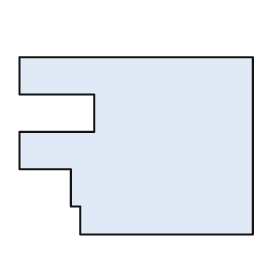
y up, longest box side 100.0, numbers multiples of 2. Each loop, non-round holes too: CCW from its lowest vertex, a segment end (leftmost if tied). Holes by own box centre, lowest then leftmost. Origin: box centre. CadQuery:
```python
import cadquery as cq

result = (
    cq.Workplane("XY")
    .moveTo(-24.0, -38.0)
    .lineTo(50.0, -38.0)
    .lineTo(50.0, 38.0)
    .lineTo(-50.0, 38.0)
    .lineTo(-50.0, 22.0)
    .lineTo(-18.0, 22.0)
    .lineTo(-18.0, 6.0)
    .lineTo(-50.0, 6.0)
    .lineTo(-50.0, -10.0)
    .lineTo(-28.0, -10.0)
    .lineTo(-28.0, -26.0)
    .lineTo(-24.0, -26.0)
    .close()
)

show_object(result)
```